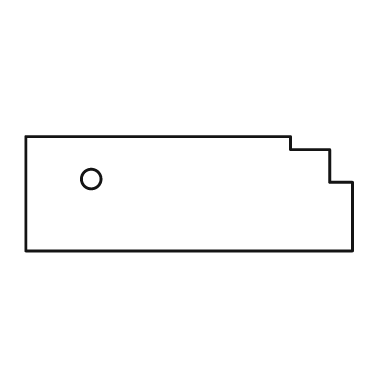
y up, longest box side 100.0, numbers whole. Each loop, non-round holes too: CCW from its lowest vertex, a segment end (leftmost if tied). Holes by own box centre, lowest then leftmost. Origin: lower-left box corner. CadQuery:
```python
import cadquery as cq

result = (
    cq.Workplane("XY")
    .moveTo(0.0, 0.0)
    .lineTo(100.0, 0.0)
    .lineTo(100.0, 21.0)
    .lineTo(93.0, 21.0)
    .lineTo(93.0, 31.0)
    .lineTo(81.0, 31.0)
    .lineTo(81.0, 35.0)
    .lineTo(0.0, 35.0)
    .close()
    .moveTo(20.0, 22.0)
    .circle(3.0)
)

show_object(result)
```